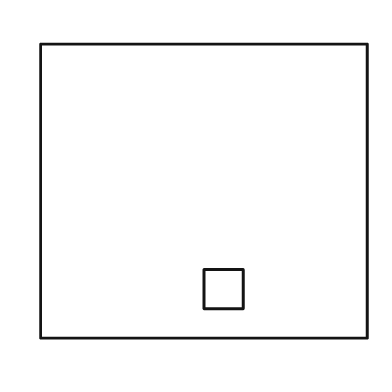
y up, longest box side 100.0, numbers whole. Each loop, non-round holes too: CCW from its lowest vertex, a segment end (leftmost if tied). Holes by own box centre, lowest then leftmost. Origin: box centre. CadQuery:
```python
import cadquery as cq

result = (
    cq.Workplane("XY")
    .moveTo(-50.0, -45.0)
    .lineTo(50.0, -45.0)
    .lineTo(50.0, 45.0)
    .lineTo(-50.0, 45.0)
    .close()
    .moveTo(0.0, -36.0)
    .lineTo(12.0, -36.0)
    .lineTo(12.0, -24.0)
    .lineTo(0.0, -24.0)
    .close()
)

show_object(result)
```